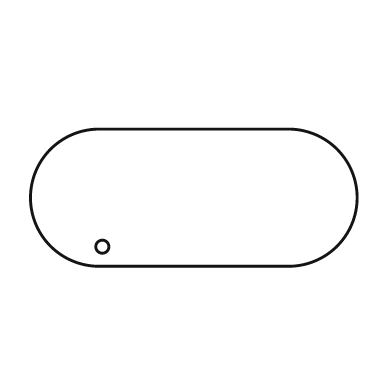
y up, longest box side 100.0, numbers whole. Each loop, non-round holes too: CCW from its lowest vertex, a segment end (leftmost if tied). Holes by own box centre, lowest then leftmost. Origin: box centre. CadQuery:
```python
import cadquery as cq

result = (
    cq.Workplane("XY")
    .moveTo(-29.0, -21.0)
    .lineTo(29.0, -21.0)
    .threePointArc((50.0, 0.0), (29.0, 21.0))
    .lineTo(-29.0, 21.0)
    .threePointArc((-50.0, 0.0), (-29.0, -21.0))
    .close()
    .moveTo(-28.0, -15.0)
    .circle(2.0)
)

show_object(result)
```